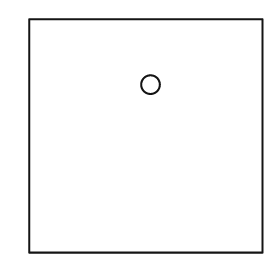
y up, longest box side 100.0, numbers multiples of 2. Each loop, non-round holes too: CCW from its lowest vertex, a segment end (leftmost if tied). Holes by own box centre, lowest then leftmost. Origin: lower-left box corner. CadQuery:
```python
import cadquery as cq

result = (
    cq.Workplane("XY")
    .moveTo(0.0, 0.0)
    .lineTo(100.0, 0.0)
    .lineTo(100.0, 100.0)
    .lineTo(0.0, 100.0)
    .close()
    .moveTo(52.0, 72.0)
    .circle(4.0)
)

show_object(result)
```